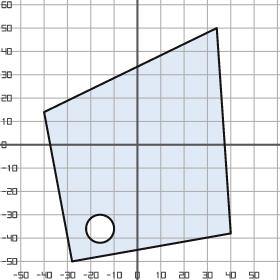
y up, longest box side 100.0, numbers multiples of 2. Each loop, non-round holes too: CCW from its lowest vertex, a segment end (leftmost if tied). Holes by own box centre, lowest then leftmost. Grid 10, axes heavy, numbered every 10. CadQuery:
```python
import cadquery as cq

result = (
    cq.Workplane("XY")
    .moveTo(-28.0, -50.0)
    .lineTo(40.0, -38.0)
    .lineTo(34.0, 50.0)
    .lineTo(-40.0, 14.0)
    .close()
    .moveTo(-16.0, -36.0)
    .circle(6.0)
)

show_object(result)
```